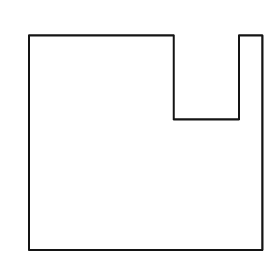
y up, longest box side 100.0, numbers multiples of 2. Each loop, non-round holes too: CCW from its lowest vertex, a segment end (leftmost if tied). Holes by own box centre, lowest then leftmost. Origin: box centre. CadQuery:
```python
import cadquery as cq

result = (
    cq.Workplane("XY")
    .moveTo(-50.0, -46.0)
    .lineTo(50.0, -46.0)
    .lineTo(50.0, 46.0)
    .lineTo(40.0, 46.0)
    .lineTo(40.0, 10.0)
    .lineTo(12.0, 10.0)
    .lineTo(12.0, 46.0)
    .lineTo(-50.0, 46.0)
    .close()
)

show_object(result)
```